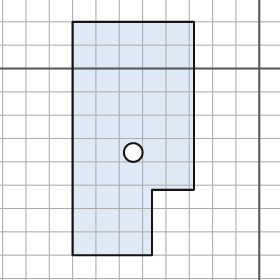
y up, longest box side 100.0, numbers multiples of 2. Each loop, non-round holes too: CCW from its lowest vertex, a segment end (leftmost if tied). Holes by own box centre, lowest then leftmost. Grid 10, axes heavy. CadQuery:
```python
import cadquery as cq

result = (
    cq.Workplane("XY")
    .moveTo(-80.0, -80.0)
    .lineTo(-46.0, -80.0)
    .lineTo(-46.0, -52.0)
    .lineTo(-28.0, -52.0)
    .lineTo(-28.0, 20.0)
    .lineTo(-80.0, 20.0)
    .close()
    .moveTo(-54.0, -36.0)
    .circle(4.0)
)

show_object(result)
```